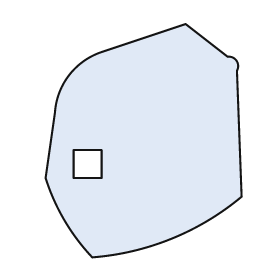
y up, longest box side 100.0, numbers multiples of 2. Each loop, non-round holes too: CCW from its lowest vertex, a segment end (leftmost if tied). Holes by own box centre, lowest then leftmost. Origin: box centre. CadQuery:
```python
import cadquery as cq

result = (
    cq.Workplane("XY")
    .moveTo(-22.0, -50.0)
    .threePointArc((12.0, -42.0), (42.0, -24.0))
    .lineTo(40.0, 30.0)
    .threePointArc((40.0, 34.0), (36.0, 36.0))
    .lineTo(18.0, 50.0)
    .lineTo(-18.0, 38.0)
    .threePointArc((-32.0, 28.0), (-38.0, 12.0))
    .lineTo(-42.0, -16.0)
    .threePointArc((-34.0, -34.0), (-22.0, -50.0))
    .close()
    .moveTo(-30.0, -16.0)
    .lineTo(-18.0, -16.0)
    .lineTo(-18.0, -4.0)
    .lineTo(-30.0, -4.0)
    .close()
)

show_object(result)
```